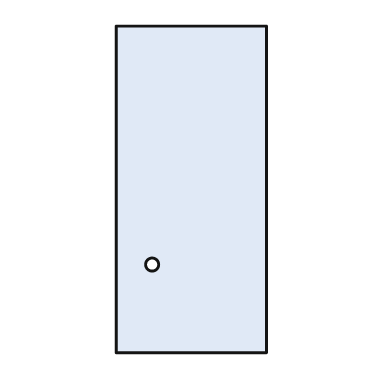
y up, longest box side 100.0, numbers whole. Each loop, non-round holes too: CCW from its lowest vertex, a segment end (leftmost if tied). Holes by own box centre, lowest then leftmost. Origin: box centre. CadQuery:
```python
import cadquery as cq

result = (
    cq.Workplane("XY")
    .moveTo(-23.0, -50.0)
    .lineTo(23.0, -50.0)
    .lineTo(23.0, 50.0)
    .lineTo(-23.0, 50.0)
    .close()
    .moveTo(-12.0, -23.0)
    .circle(2.0)
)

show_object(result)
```